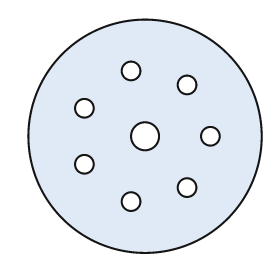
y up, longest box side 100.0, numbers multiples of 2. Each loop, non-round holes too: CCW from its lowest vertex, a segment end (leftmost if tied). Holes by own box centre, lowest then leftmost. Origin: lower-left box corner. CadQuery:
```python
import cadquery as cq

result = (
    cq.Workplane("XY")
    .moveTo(50.0, 50.0)
    .circle(50.0)
    .moveTo(44.0, 22.0)
    .circle(4.0)
    .moveTo(68.0, 28.0)
    .circle(4.0)
    .moveTo(24.0, 38.0)
    .circle(4.0)
    .moveTo(50.0, 50.0)
    .circle(6.0)
    .moveTo(78.0, 50.0)
    .circle(4.0)
    .moveTo(24.0, 62.0)
    .circle(4.0)
    .moveTo(68.0, 72.0)
    .circle(4.0)
    .moveTo(44.0, 78.0)
    .circle(4.0)
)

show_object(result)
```